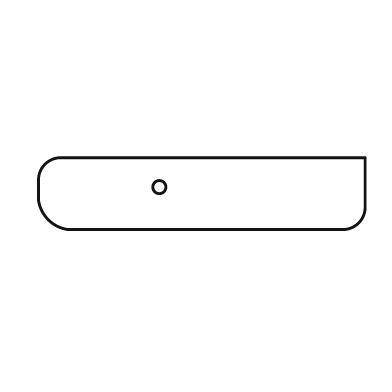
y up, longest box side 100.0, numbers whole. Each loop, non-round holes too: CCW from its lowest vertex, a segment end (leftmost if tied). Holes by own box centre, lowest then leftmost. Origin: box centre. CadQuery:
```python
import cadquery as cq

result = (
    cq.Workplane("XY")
    .moveTo(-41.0, -11.0)
    .lineTo(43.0, -11.0)
    .threePointArc((48.0, -9.0), (50.0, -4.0))
    .lineTo(50.0, 11.0)
    .lineTo(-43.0, 11.0)
    .threePointArc((-48.0, 9.0), (-50.0, 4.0))
    .lineTo(-50.0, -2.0)
    .threePointArc((-47.0, -8.0), (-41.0, -11.0))
    .close()
    .moveTo(-13.0, 2.0)
    .circle(2.0)
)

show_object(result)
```